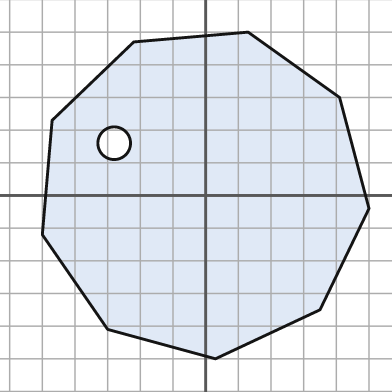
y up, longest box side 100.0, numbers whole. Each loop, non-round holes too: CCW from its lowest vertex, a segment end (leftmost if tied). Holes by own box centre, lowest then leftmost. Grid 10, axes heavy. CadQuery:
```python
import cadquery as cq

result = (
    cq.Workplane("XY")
    .moveTo(3.0, -50.0)
    .lineTo(35.0, -35.0)
    .lineTo(50.0, -4.0)
    .lineTo(41.0, 30.0)
    .lineTo(13.0, 50.0)
    .lineTo(-22.0, 47.0)
    .lineTo(-47.0, 23.0)
    .lineTo(-50.0, -12.0)
    .lineTo(-30.0, -41.0)
    .close()
    .moveTo(-28.0, 16.0)
    .circle(5.0)
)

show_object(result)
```